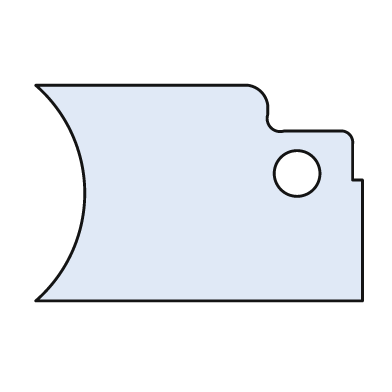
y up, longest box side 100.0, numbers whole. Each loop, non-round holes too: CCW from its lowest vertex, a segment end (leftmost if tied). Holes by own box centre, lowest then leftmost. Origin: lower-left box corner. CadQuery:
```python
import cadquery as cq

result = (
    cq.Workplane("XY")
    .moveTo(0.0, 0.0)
    .lineTo(100.0, 0.0)
    .lineTo(100.0, 37.0)
    .lineTo(97.0, 37.0)
    .lineTo(97.0, 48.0)
    .threePointArc((96.0, 51.0), (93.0, 52.0))
    .lineTo(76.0, 52.0)
    .threePointArc((72.0, 53.0), (71.0, 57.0))
    .lineTo(71.0, 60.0)
    .threePointArc((69.0, 64.0), (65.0, 66.0))
    .lineTo(0.0, 66.0)
    .threePointArc((15.0, 33.0), (0.0, 0.0))
    .close()
    .moveTo(80.0, 39.0)
    .circle(7.0)
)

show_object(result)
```